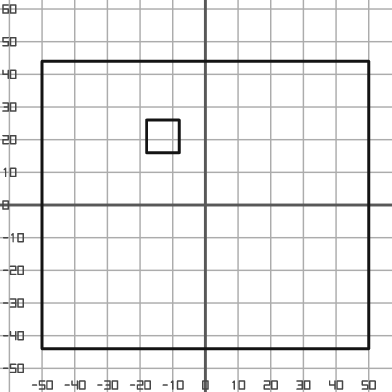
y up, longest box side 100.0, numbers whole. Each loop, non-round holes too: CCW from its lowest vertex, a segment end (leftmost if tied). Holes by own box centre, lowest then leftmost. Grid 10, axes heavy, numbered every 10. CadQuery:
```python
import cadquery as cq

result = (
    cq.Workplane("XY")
    .moveTo(-50.0, -44.0)
    .lineTo(50.0, -44.0)
    .lineTo(50.0, 44.0)
    .lineTo(-50.0, 44.0)
    .close()
    .moveTo(-18.0, 16.0)
    .lineTo(-8.0, 16.0)
    .lineTo(-8.0, 26.0)
    .lineTo(-18.0, 26.0)
    .close()
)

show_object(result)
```